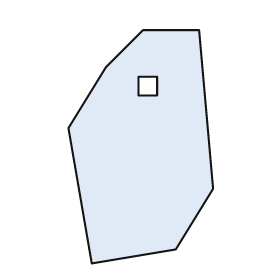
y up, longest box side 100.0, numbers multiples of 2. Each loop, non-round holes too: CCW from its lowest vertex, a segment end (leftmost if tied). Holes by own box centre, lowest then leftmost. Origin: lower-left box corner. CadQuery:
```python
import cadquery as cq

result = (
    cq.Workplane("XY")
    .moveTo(10.0, 0.0)
    .lineTo(46.0, 6.0)
    .lineTo(62.0, 32.0)
    .lineTo(56.0, 100.0)
    .lineTo(32.0, 100.0)
    .lineTo(16.0, 84.0)
    .lineTo(0.0, 58.0)
    .close()
    .moveTo(30.0, 72.0)
    .lineTo(38.0, 72.0)
    .lineTo(38.0, 80.0)
    .lineTo(30.0, 80.0)
    .close()
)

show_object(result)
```